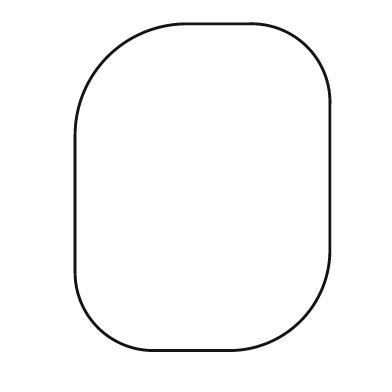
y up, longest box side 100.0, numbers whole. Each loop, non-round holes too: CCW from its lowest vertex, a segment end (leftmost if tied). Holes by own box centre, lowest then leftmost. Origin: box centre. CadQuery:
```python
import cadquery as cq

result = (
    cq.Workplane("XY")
    .moveTo(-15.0, -50.0)
    .lineTo(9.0, -50.0)
    .threePointArc((30.0, -41.0), (39.0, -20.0))
    .lineTo(39.0, 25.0)
    .threePointArc((32.0, 43.0), (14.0, 50.0))
    .lineTo(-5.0, 50.0)
    .threePointArc((-29.0, 40.0), (-39.0, 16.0))
    .lineTo(-39.0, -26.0)
    .threePointArc((-32.0, -43.0), (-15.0, -50.0))
    .close()
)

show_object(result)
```